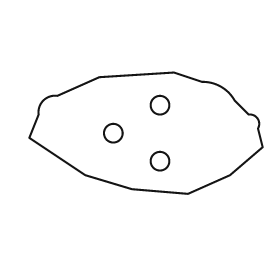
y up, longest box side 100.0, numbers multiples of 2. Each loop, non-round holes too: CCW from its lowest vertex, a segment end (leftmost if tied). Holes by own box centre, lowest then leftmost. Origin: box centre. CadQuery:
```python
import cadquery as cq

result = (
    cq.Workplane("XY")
    .moveTo(18.0, -26.0)
    .lineTo(36.0, -18.0)
    .lineTo(50.0, -6.0)
    .lineTo(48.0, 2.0)
    .threePointArc((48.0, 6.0), (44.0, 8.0))
    .lineTo(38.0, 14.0)
    .threePointArc((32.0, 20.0), (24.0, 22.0))
    .lineTo(12.0, 26.0)
    .lineTo(-20.0, 24.0)
    .lineTo(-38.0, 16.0)
    .threePointArc((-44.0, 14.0), (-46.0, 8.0))
    .lineTo(-50.0, -2.0)
    .lineTo(-26.0, -18.0)
    .lineTo(-6.0, -24.0)
    .close()
    .moveTo(6.0, -12.0)
    .circle(4.0)
    .moveTo(-14.0, 0.0)
    .circle(4.0)
    .moveTo(6.0, 12.0)
    .circle(4.0)
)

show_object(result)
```